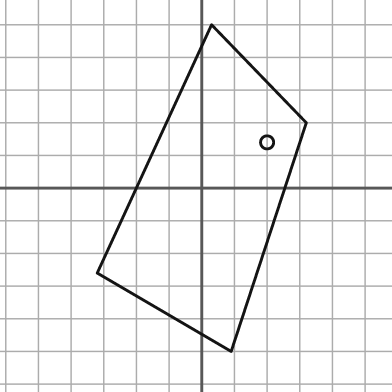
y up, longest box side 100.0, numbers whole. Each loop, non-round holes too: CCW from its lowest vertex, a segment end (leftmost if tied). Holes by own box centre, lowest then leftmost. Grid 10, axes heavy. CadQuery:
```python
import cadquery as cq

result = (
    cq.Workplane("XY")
    .moveTo(9.0, -50.0)
    .lineTo(32.0, 20.0)
    .lineTo(3.0, 50.0)
    .lineTo(-32.0, -26.0)
    .close()
    .moveTo(20.0, 14.0)
    .circle(2.0)
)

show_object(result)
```